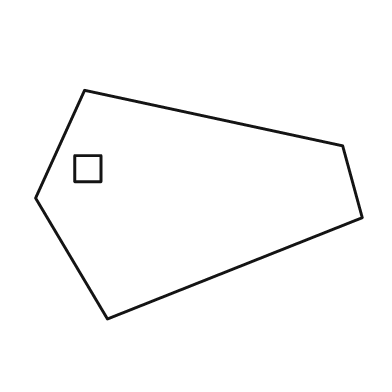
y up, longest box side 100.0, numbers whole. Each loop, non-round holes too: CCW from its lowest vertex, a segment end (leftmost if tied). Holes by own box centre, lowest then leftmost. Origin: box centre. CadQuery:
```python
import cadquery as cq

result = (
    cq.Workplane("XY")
    .moveTo(-28.0, -35.0)
    .lineTo(50.0, -4.0)
    .lineTo(44.0, 18.0)
    .lineTo(-35.0, 35.0)
    .lineTo(-50.0, 2.0)
    .close()
    .moveTo(-38.0, 7.0)
    .lineTo(-30.0, 7.0)
    .lineTo(-30.0, 15.0)
    .lineTo(-38.0, 15.0)
    .close()
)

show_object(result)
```